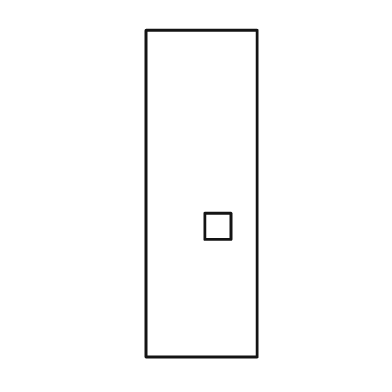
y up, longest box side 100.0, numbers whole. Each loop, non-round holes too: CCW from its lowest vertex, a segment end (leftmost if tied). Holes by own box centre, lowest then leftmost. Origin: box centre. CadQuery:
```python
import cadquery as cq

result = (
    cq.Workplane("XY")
    .moveTo(-17.0, -50.0)
    .lineTo(17.0, -50.0)
    .lineTo(17.0, 50.0)
    .lineTo(-17.0, 50.0)
    .close()
    .moveTo(1.0, -14.0)
    .lineTo(9.0, -14.0)
    .lineTo(9.0, -6.0)
    .lineTo(1.0, -6.0)
    .close()
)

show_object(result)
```